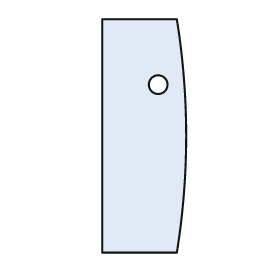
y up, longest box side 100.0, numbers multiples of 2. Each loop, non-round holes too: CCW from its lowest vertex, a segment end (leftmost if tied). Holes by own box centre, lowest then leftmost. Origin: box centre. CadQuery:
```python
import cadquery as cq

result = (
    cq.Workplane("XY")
    .moveTo(-18.0, -50.0)
    .lineTo(14.0, -50.0)
    .threePointArc((18.0, 0.0), (14.0, 50.0))
    .lineTo(-18.0, 50.0)
    .close()
    .moveTo(6.0, 22.0)
    .circle(4.0)
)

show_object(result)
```